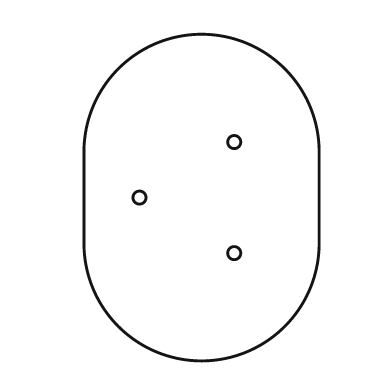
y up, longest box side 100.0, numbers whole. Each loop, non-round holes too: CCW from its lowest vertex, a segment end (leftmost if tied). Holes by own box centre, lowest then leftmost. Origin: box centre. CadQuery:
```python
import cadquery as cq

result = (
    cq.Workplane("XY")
    .moveTo(-36.0, -14.0)
    .threePointArc((0.0, -50.0), (36.0, -14.0))
    .lineTo(36.0, 14.0)
    .threePointArc((0.0, 50.0), (-36.0, 14.0))
    .close()
    .moveTo(10.0, -17.0)
    .circle(2.0)
    .moveTo(-19.0, 0.0)
    .circle(2.0)
    .moveTo(10.0, 17.0)
    .circle(2.0)
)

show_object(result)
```